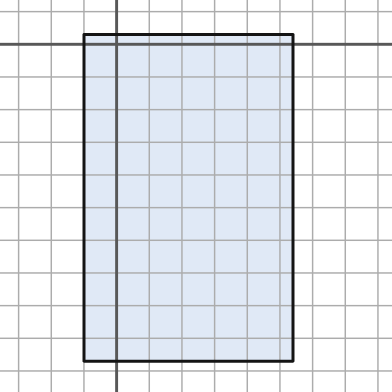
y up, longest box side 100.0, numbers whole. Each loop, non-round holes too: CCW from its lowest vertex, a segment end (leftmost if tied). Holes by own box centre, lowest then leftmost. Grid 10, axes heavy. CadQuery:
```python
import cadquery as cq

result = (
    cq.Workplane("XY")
    .moveTo(-10.0, -97.0)
    .lineTo(54.0, -97.0)
    .lineTo(54.0, 3.0)
    .lineTo(-10.0, 3.0)
    .close()
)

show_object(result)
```